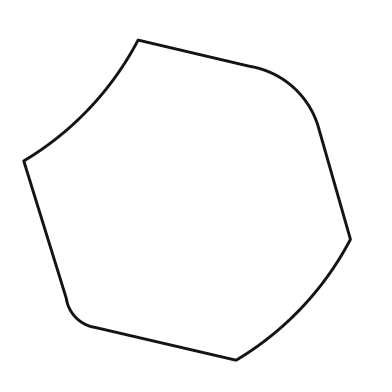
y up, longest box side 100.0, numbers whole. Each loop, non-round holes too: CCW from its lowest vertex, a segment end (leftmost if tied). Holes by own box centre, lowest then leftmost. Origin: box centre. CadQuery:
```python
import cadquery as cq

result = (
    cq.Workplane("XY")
    .moveTo(15.0, -49.0)
    .threePointArc((35.0, -33.0), (50.0, -12.0))
    .lineTo(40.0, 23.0)
    .threePointArc((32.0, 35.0), (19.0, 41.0))
    .lineTo(-15.0, 49.0)
    .threePointArc((-30.0, 28.0), (-50.0, 12.0))
    .lineTo(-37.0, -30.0)
    .threePointArc((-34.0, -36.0), (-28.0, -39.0))
    .close()
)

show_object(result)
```